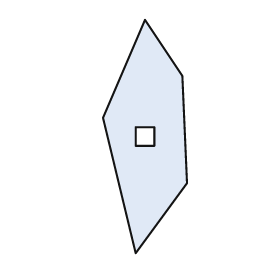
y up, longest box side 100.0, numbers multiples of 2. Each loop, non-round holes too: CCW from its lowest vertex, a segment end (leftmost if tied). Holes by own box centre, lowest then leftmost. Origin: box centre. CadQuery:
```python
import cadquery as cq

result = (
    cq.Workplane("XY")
    .moveTo(-4.0, -50.0)
    .lineTo(18.0, -20.0)
    .lineTo(16.0, 26.0)
    .lineTo(0.0, 50.0)
    .lineTo(-18.0, 8.0)
    .close()
    .moveTo(-4.0, -4.0)
    .lineTo(4.0, -4.0)
    .lineTo(4.0, 4.0)
    .lineTo(-4.0, 4.0)
    .close()
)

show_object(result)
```